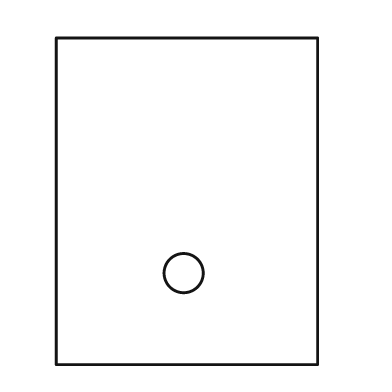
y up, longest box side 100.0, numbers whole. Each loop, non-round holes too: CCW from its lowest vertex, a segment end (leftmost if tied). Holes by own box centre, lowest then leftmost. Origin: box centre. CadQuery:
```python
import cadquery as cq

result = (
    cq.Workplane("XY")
    .moveTo(-40.0, -50.0)
    .lineTo(40.0, -50.0)
    .lineTo(40.0, 50.0)
    .lineTo(-40.0, 50.0)
    .close()
    .moveTo(-1.0, -22.0)
    .circle(6.0)
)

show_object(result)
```